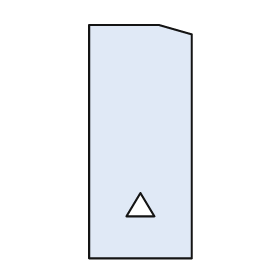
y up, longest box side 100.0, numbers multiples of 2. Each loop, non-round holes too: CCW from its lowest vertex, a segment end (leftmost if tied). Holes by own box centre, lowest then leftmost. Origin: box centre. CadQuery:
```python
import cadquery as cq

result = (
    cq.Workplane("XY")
    .moveTo(-22.0, -50.0)
    .lineTo(22.0, -50.0)
    .lineTo(22.0, 46.0)
    .lineTo(8.0, 50.0)
    .lineTo(-22.0, 50.0)
    .close()
    .moveTo(-6.0, -32.0)
    .lineTo(6.0, -32.0)
    .lineTo(0.0, -22.0)
    .close()
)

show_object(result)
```